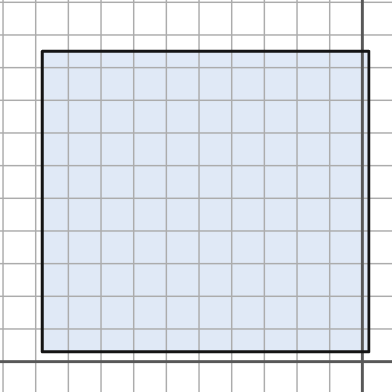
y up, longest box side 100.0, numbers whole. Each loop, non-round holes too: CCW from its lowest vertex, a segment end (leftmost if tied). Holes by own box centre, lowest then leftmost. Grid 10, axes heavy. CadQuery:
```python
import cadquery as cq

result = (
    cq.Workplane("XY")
    .moveTo(-98.0, 3.0)
    .lineTo(2.0, 3.0)
    .lineTo(2.0, 95.0)
    .lineTo(-98.0, 95.0)
    .close()
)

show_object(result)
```